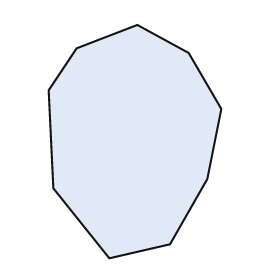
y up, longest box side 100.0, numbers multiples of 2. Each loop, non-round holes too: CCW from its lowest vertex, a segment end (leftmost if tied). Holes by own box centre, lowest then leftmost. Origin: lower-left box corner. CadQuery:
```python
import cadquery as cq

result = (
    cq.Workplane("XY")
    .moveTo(26.0, 0.0)
    .lineTo(52.0, 6.0)
    .lineTo(68.0, 34.0)
    .lineTo(74.0, 64.0)
    .lineTo(60.0, 88.0)
    .lineTo(38.0, 100.0)
    .lineTo(12.0, 90.0)
    .lineTo(0.0, 72.0)
    .lineTo(2.0, 30.0)
    .close()
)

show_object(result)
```